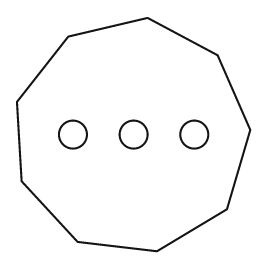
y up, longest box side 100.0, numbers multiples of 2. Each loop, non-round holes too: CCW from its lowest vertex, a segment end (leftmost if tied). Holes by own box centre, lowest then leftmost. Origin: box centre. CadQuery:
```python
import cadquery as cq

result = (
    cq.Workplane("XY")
    .moveTo(10.0, -50.0)
    .lineTo(40.0, -32.0)
    .lineTo(50.0, 2.0)
    .lineTo(36.0, 34.0)
    .lineTo(6.0, 50.0)
    .lineTo(-28.0, 42.0)
    .lineTo(-50.0, 14.0)
    .lineTo(-48.0, -20.0)
    .lineTo(-24.0, -46.0)
    .close()
    .moveTo(-26.0, 0.0)
    .circle(6.0)
    .moveTo(0.0, 0.0)
    .circle(6.0)
    .moveTo(26.0, 0.0)
    .circle(6.0)
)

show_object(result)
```